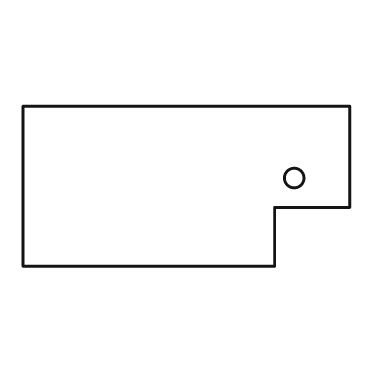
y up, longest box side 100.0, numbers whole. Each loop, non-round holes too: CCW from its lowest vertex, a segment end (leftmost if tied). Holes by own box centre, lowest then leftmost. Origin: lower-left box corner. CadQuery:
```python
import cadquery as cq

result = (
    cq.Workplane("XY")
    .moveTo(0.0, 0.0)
    .lineTo(77.0, 0.0)
    .lineTo(77.0, 18.0)
    .lineTo(100.0, 18.0)
    .lineTo(100.0, 49.0)
    .lineTo(0.0, 49.0)
    .close()
    .moveTo(83.0, 27.0)
    .circle(3.0)
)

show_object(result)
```